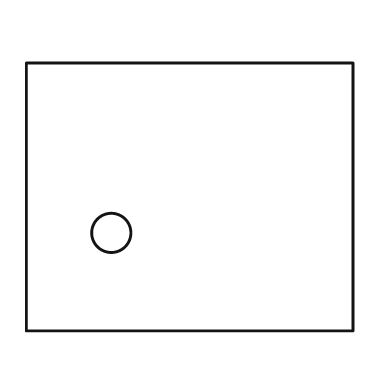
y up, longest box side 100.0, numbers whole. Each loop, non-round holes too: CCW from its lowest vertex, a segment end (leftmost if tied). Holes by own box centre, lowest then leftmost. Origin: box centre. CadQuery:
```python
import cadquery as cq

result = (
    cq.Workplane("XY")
    .moveTo(-50.0, -41.0)
    .lineTo(50.0, -41.0)
    .lineTo(50.0, 41.0)
    .lineTo(-50.0, 41.0)
    .close()
    .moveTo(-24.0, -11.0)
    .circle(6.0)
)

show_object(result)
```